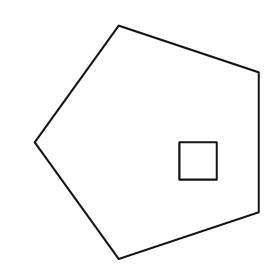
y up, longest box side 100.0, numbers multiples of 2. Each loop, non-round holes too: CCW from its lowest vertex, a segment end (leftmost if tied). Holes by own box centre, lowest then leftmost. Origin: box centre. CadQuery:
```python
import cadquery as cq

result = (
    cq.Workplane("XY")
    .moveTo(-12.0, -50.0)
    .lineTo(48.0, -30.0)
    .lineTo(48.0, 30.0)
    .lineTo(-12.0, 50.0)
    .lineTo(-48.0, 0.0)
    .close()
    .moveTo(14.0, -16.0)
    .lineTo(30.0, -16.0)
    .lineTo(30.0, 0.0)
    .lineTo(14.0, 0.0)
    .close()
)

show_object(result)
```